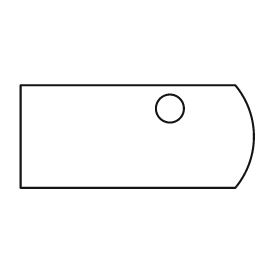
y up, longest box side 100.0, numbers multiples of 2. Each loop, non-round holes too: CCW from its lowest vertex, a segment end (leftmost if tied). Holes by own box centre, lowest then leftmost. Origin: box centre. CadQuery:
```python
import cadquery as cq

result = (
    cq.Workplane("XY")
    .moveTo(-50.0, -22.0)
    .lineTo(42.0, -22.0)
    .threePointArc((50.0, 0.0), (42.0, 22.0))
    .lineTo(-50.0, 22.0)
    .close()
    .moveTo(14.0, 12.0)
    .circle(6.0)
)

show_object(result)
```